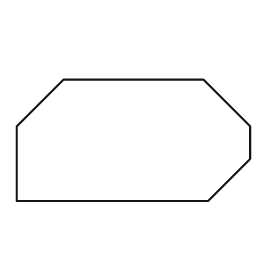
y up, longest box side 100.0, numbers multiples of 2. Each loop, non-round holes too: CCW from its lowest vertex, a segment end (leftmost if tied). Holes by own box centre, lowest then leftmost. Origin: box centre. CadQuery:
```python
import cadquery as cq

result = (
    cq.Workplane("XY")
    .moveTo(-50.0, -26.0)
    .lineTo(32.0, -26.0)
    .lineTo(50.0, -8.0)
    .lineTo(50.0, 6.0)
    .lineTo(30.0, 26.0)
    .lineTo(-30.0, 26.0)
    .lineTo(-50.0, 6.0)
    .close()
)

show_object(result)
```